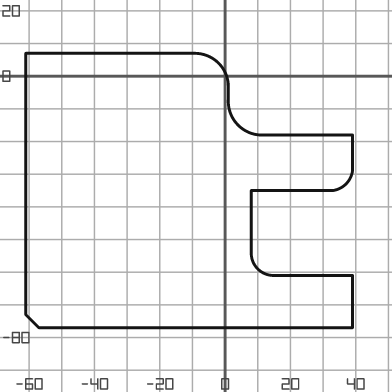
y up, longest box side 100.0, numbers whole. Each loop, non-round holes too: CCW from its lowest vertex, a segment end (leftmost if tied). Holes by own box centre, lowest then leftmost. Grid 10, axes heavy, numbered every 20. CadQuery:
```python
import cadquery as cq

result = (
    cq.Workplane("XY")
    .moveTo(-57.0, -77.0)
    .lineTo(39.0, -77.0)
    .lineTo(39.0, -61.0)
    .lineTo(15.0, -61.0)
    .threePointArc((10.0, -59.0), (8.0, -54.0))
    .lineTo(8.0, -35.0)
    .lineTo(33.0, -35.0)
    .threePointArc((37.0, -33.0), (39.0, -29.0))
    .lineTo(39.0, -18.0)
    .lineTo(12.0, -18.0)
    .threePointArc((4.0, -15.0), (1.0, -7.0))
    .lineTo(1.0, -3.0)
    .threePointArc((-2.0, 4.0), (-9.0, 7.0))
    .lineTo(-61.0, 7.0)
    .lineTo(-61.0, -73.0)
    .close()
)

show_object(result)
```